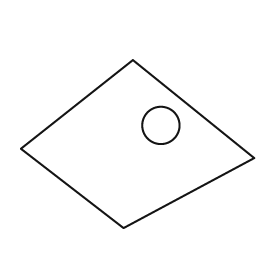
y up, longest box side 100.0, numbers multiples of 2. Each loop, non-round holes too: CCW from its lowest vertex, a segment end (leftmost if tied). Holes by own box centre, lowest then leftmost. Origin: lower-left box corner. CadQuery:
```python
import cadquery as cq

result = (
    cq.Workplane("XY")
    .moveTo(44.0, 0.0)
    .lineTo(100.0, 30.0)
    .lineTo(48.0, 72.0)
    .lineTo(0.0, 34.0)
    .close()
    .moveTo(60.0, 44.0)
    .circle(8.0)
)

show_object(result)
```